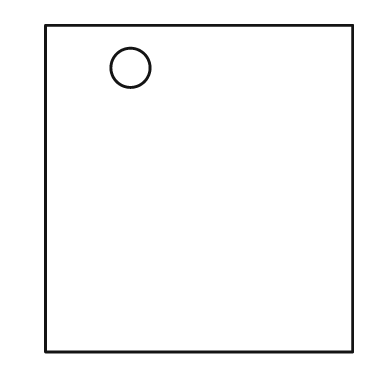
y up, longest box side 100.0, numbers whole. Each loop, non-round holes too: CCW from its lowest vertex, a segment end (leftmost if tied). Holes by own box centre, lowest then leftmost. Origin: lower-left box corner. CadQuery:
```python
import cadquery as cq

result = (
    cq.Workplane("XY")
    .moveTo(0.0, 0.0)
    .lineTo(94.0, 0.0)
    .lineTo(94.0, 100.0)
    .lineTo(0.0, 100.0)
    .close()
    .moveTo(26.0, 87.0)
    .circle(6.0)
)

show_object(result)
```